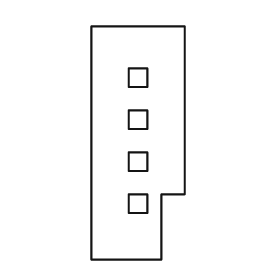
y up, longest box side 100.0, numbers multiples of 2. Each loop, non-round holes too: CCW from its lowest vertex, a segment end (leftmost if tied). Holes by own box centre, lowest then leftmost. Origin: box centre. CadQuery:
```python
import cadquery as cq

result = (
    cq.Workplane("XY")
    .moveTo(-20.0, -50.0)
    .lineTo(10.0, -50.0)
    .lineTo(10.0, -22.0)
    .lineTo(20.0, -22.0)
    .lineTo(20.0, 50.0)
    .lineTo(-20.0, 50.0)
    .close()
    .moveTo(-4.0, -30.0)
    .lineTo(4.0, -30.0)
    .lineTo(4.0, -22.0)
    .lineTo(-4.0, -22.0)
    .close()
    .moveTo(-4.0, -12.0)
    .lineTo(4.0, -12.0)
    .lineTo(4.0, -4.0)
    .lineTo(-4.0, -4.0)
    .close()
    .moveTo(-4.0, 6.0)
    .lineTo(4.0, 6.0)
    .lineTo(4.0, 14.0)
    .lineTo(-4.0, 14.0)
    .close()
    .moveTo(-4.0, 24.0)
    .lineTo(4.0, 24.0)
    .lineTo(4.0, 32.0)
    .lineTo(-4.0, 32.0)
    .close()
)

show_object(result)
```